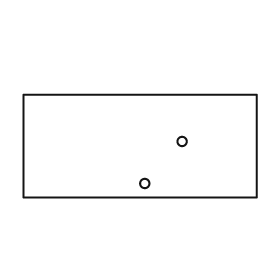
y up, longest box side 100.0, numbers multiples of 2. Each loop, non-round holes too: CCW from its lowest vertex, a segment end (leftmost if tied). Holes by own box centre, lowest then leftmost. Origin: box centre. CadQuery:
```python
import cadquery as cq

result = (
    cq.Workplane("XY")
    .moveTo(-50.0, -22.0)
    .lineTo(50.0, -22.0)
    .lineTo(50.0, 22.0)
    .lineTo(-50.0, 22.0)
    .close()
    .moveTo(2.0, -16.0)
    .circle(2.0)
    .moveTo(18.0, 2.0)
    .circle(2.0)
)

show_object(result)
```